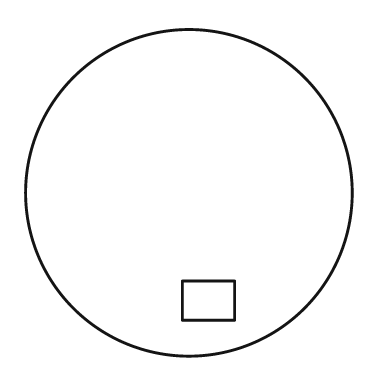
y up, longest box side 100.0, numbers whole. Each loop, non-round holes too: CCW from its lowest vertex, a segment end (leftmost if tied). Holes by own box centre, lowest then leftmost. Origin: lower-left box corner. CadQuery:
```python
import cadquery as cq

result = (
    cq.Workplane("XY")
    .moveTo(50.0, 50.0)
    .circle(50.0)
    .moveTo(48.0, 11.0)
    .lineTo(64.0, 11.0)
    .lineTo(64.0, 23.0)
    .lineTo(48.0, 23.0)
    .close()
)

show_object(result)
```